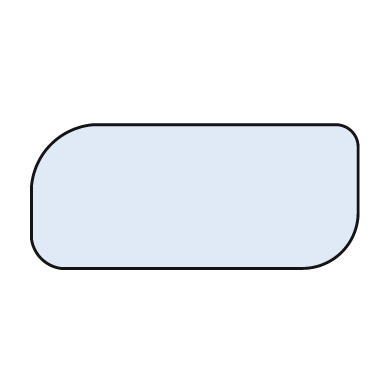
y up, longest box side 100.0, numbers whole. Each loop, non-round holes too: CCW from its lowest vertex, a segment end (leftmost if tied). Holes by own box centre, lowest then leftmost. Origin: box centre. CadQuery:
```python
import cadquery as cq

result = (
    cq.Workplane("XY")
    .moveTo(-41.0, -22.0)
    .lineTo(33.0, -22.0)
    .threePointArc((45.0, -17.0), (50.0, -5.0))
    .lineTo(50.0, 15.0)
    .threePointArc((48.0, 20.0), (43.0, 22.0))
    .lineTo(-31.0, 22.0)
    .threePointArc((-44.0, 16.0), (-50.0, 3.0))
    .lineTo(-50.0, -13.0)
    .threePointArc((-47.0, -19.0), (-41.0, -22.0))
    .close()
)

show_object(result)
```